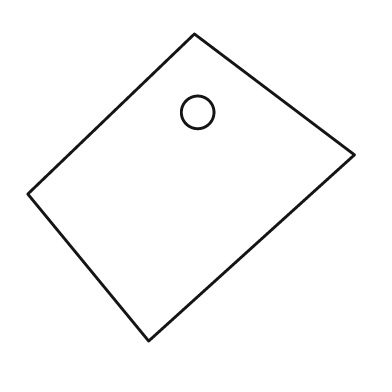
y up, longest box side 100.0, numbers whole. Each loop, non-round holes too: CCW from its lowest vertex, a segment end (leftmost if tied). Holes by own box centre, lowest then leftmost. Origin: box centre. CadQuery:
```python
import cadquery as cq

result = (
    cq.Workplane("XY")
    .moveTo(-13.0, -47.0)
    .lineTo(50.0, 10.0)
    .lineTo(1.0, 47.0)
    .lineTo(-50.0, -2.0)
    .close()
    .moveTo(2.0, 23.0)
    .circle(5.0)
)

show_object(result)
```